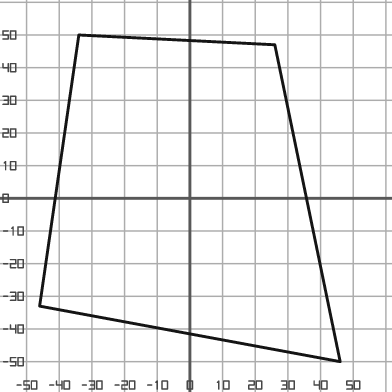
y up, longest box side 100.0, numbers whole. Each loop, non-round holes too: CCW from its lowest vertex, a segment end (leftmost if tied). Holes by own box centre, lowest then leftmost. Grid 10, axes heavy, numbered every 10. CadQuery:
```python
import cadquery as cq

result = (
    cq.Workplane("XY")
    .moveTo(46.0, -50.0)
    .lineTo(26.0, 47.0)
    .lineTo(-34.0, 50.0)
    .lineTo(-46.0, -33.0)
    .close()
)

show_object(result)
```